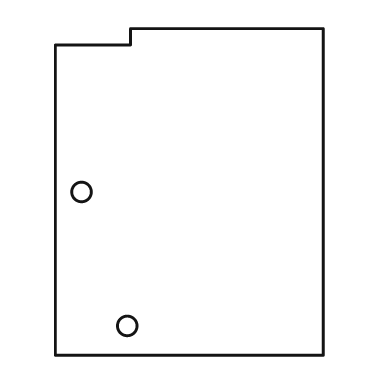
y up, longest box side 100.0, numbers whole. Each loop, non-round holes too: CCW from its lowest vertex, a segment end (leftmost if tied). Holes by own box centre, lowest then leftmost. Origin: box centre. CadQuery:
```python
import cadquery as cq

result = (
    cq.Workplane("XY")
    .moveTo(-41.0, -50.0)
    .lineTo(41.0, -50.0)
    .lineTo(41.0, 50.0)
    .lineTo(-18.0, 50.0)
    .lineTo(-18.0, 45.0)
    .lineTo(-41.0, 45.0)
    .close()
    .moveTo(-19.0, -41.0)
    .circle(3.0)
    .moveTo(-33.0, 0.0)
    .circle(3.0)
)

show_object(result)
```